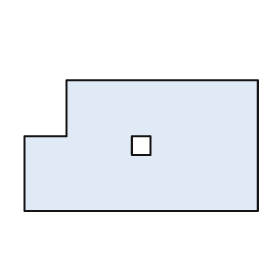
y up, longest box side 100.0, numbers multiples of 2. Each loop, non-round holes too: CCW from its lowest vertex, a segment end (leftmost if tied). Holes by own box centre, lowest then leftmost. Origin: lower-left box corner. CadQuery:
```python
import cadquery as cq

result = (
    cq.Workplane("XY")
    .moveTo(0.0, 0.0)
    .lineTo(100.0, 0.0)
    .lineTo(100.0, 56.0)
    .lineTo(18.0, 56.0)
    .lineTo(18.0, 32.0)
    .lineTo(0.0, 32.0)
    .close()
    .moveTo(46.0, 24.0)
    .lineTo(54.0, 24.0)
    .lineTo(54.0, 32.0)
    .lineTo(46.0, 32.0)
    .close()
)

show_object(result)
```